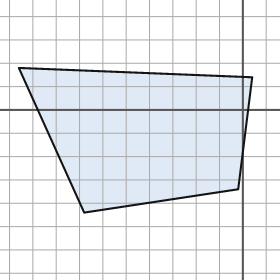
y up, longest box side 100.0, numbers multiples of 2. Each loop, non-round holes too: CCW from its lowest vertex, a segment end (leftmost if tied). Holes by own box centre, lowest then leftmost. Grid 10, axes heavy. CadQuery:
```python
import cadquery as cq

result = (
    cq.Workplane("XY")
    .moveTo(-68.0, -44.0)
    .lineTo(-2.0, -34.0)
    .lineTo(4.0, 14.0)
    .lineTo(-96.0, 18.0)
    .close()
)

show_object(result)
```